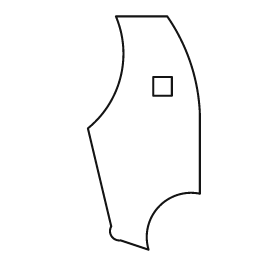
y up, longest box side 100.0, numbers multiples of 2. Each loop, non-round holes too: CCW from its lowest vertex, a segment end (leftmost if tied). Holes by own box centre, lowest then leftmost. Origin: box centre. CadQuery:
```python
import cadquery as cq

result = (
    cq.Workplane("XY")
    .moveTo(2.0, -50.0)
    .threePointArc((6.0, -32.0), (24.0, -26.0))
    .lineTo(24.0, 8.0)
    .threePointArc((20.0, 30.0), (10.0, 50.0))
    .lineTo(-12.0, 50.0)
    .threePointArc((-10.0, 24.0), (-24.0, 2.0))
    .lineTo(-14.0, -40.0)
    .threePointArc((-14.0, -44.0), (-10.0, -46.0))
    .close()
    .moveTo(4.0, 16.0)
    .lineTo(12.0, 16.0)
    .lineTo(12.0, 24.0)
    .lineTo(4.0, 24.0)
    .close()
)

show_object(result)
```